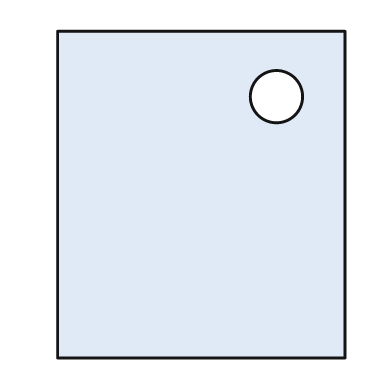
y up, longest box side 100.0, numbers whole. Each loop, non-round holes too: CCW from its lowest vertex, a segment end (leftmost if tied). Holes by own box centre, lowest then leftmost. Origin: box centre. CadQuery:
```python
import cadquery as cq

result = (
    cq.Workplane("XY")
    .moveTo(-44.0, -50.0)
    .lineTo(44.0, -50.0)
    .lineTo(44.0, 50.0)
    .lineTo(-44.0, 50.0)
    .close()
    .moveTo(23.0, 30.0)
    .circle(8.0)
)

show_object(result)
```